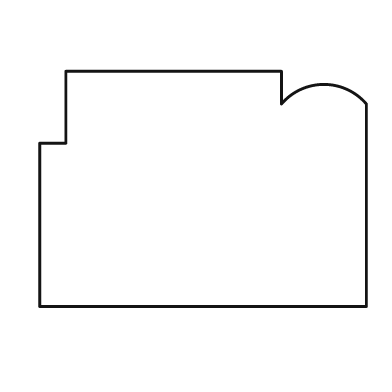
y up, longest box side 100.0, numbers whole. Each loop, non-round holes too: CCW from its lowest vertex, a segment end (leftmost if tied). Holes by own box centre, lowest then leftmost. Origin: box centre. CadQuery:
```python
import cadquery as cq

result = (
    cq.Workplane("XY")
    .moveTo(-50.0, -36.0)
    .lineTo(50.0, -36.0)
    .lineTo(50.0, 26.0)
    .threePointArc((37.0, 32.0), (24.0, 26.0))
    .lineTo(24.0, 36.0)
    .lineTo(-42.0, 36.0)
    .lineTo(-42.0, 14.0)
    .lineTo(-50.0, 14.0)
    .close()
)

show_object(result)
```